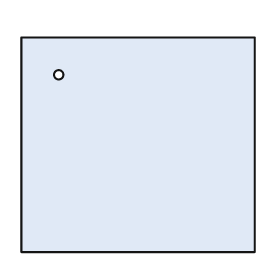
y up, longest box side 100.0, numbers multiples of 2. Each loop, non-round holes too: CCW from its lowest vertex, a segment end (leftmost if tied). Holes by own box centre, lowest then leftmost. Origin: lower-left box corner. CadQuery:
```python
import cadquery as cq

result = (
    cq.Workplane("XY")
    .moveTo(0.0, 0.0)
    .lineTo(100.0, 0.0)
    .lineTo(100.0, 92.0)
    .lineTo(0.0, 92.0)
    .close()
    .moveTo(16.0, 76.0)
    .circle(2.0)
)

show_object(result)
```